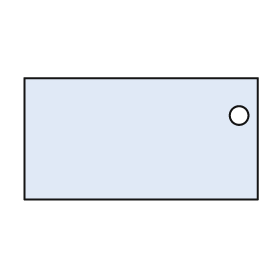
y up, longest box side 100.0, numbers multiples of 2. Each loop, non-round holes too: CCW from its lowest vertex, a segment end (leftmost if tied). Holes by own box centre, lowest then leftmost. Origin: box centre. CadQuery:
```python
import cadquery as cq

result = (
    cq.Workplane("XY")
    .moveTo(-50.0, -26.0)
    .lineTo(50.0, -26.0)
    .lineTo(50.0, 26.0)
    .lineTo(-50.0, 26.0)
    .close()
    .moveTo(42.0, 10.0)
    .circle(4.0)
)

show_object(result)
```